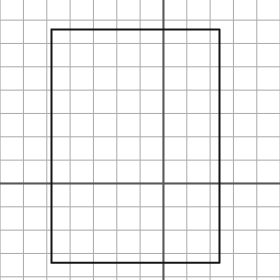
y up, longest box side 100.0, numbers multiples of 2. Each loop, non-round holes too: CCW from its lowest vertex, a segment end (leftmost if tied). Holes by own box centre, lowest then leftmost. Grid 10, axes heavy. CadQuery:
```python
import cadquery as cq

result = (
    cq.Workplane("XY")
    .moveTo(-48.0, -34.0)
    .lineTo(24.0, -34.0)
    .lineTo(24.0, 66.0)
    .lineTo(-48.0, 66.0)
    .close()
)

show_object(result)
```